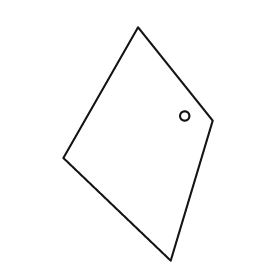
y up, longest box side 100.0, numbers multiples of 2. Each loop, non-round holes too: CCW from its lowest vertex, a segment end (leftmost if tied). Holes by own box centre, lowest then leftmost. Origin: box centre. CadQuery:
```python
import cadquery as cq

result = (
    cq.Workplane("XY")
    .moveTo(14.0, -50.0)
    .lineTo(32.0, 10.0)
    .lineTo(0.0, 50.0)
    .lineTo(-32.0, -6.0)
    .close()
    .moveTo(20.0, 12.0)
    .circle(2.0)
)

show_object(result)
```